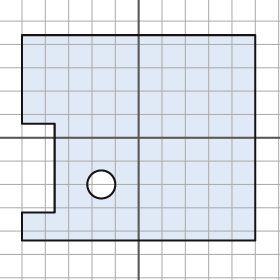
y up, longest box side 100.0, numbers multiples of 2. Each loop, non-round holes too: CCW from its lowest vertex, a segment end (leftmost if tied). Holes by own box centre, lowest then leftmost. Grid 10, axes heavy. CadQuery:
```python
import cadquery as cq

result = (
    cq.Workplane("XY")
    .moveTo(-50.0, -44.0)
    .lineTo(50.0, -44.0)
    .lineTo(50.0, 44.0)
    .lineTo(-50.0, 44.0)
    .lineTo(-50.0, 6.0)
    .lineTo(-36.0, 6.0)
    .lineTo(-36.0, -32.0)
    .lineTo(-50.0, -32.0)
    .close()
    .moveTo(-16.0, -20.0)
    .circle(6.0)
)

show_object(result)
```